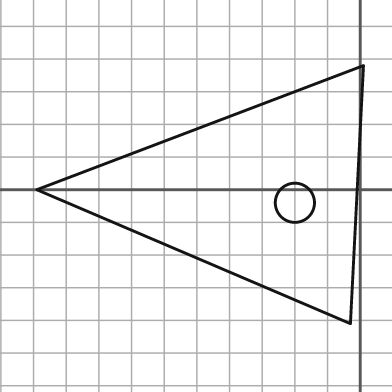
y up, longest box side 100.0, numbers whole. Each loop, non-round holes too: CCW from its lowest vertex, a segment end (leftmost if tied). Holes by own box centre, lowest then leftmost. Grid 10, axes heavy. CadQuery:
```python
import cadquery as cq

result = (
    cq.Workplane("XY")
    .moveTo(-3.0, -41.0)
    .lineTo(1.0, 38.0)
    .lineTo(-99.0, 0.0)
    .close()
    .moveTo(-20.0, -4.0)
    .circle(6.0)
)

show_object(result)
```